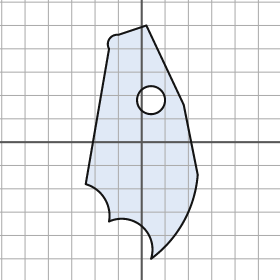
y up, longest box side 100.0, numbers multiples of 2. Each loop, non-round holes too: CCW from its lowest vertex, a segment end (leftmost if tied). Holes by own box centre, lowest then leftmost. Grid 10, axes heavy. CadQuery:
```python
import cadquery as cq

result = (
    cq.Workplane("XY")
    .moveTo(4.0, -50.0)
    .threePointArc((18.0, -34.0), (24.0, -14.0))
    .lineTo(18.0, 16.0)
    .lineTo(2.0, 50.0)
    .lineTo(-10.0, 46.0)
    .threePointArc((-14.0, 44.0), (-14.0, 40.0))
    .lineTo(-24.0, -18.0)
    .threePointArc((-16.0, -24.0), (-14.0, -34.0))
    .threePointArc((0.0, -36.0), (4.0, -50.0))
    .close()
    .moveTo(4.0, 18.0)
    .circle(6.0)
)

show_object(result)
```